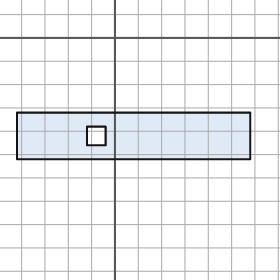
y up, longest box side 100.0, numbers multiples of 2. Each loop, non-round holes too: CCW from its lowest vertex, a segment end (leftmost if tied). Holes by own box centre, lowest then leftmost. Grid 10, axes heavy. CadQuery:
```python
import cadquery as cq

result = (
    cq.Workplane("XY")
    .moveTo(-42.0, -52.0)
    .lineTo(58.0, -52.0)
    .lineTo(58.0, -32.0)
    .lineTo(-42.0, -32.0)
    .close()
    .moveTo(-12.0, -46.0)
    .lineTo(-4.0, -46.0)
    .lineTo(-4.0, -38.0)
    .lineTo(-12.0, -38.0)
    .close()
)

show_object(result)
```